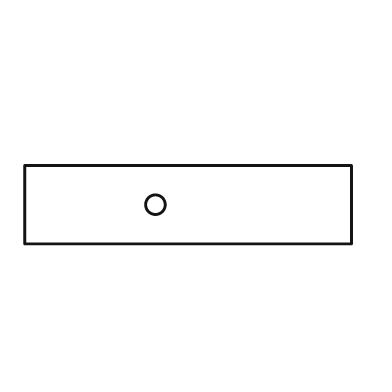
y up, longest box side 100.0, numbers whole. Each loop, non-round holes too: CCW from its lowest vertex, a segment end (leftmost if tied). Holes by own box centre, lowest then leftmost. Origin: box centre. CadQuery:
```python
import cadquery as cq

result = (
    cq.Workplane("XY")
    .moveTo(-50.0, -12.0)
    .lineTo(50.0, -12.0)
    .lineTo(50.0, 12.0)
    .lineTo(-50.0, 12.0)
    .close()
    .moveTo(-10.0, 0.0)
    .circle(3.0)
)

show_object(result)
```